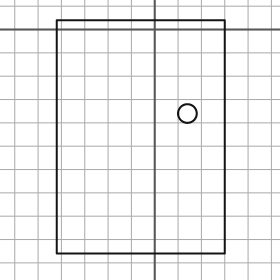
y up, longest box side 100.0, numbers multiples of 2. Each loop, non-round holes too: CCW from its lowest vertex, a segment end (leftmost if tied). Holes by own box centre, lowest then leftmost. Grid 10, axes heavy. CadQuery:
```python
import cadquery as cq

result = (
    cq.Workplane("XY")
    .moveTo(-42.0, -96.0)
    .lineTo(30.0, -96.0)
    .lineTo(30.0, 4.0)
    .lineTo(-42.0, 4.0)
    .close()
    .moveTo(14.0, -36.0)
    .circle(4.0)
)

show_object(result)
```